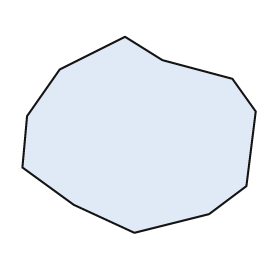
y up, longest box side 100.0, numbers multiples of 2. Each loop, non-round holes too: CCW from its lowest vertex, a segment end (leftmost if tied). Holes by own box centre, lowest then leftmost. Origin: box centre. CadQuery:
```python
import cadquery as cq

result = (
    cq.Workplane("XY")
    .moveTo(-2.0, -42.0)
    .lineTo(30.0, -34.0)
    .lineTo(46.0, -22.0)
    .lineTo(50.0, 10.0)
    .lineTo(40.0, 24.0)
    .lineTo(10.0, 32.0)
    .lineTo(-6.0, 42.0)
    .lineTo(-34.0, 28.0)
    .lineTo(-48.0, 8.0)
    .lineTo(-50.0, -14.0)
    .lineTo(-28.0, -30.0)
    .close()
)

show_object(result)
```